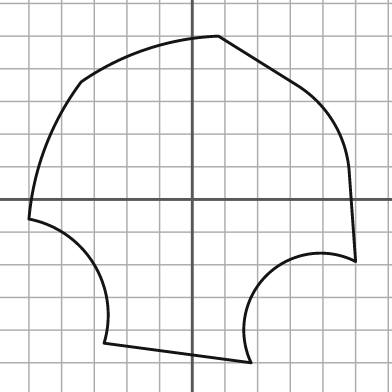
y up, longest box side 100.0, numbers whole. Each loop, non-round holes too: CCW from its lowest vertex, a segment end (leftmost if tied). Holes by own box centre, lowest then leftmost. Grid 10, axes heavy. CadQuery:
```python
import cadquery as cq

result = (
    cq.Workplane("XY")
    .moveTo(18.0, -50.0)
    .threePointArc((23.0, -23.0), (50.0, -19.0))
    .lineTo(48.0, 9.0)
    .threePointArc((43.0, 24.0), (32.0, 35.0))
    .lineTo(8.0, 50.0)
    .threePointArc((-14.0, 46.0), (-34.0, 36.0))
    .threePointArc((-45.0, 16.0), (-50.0, -6.0))
    .threePointArc((-30.0, -20.0), (-27.0, -44.0))
    .close()
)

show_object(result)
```